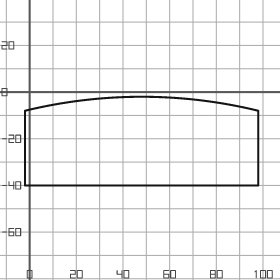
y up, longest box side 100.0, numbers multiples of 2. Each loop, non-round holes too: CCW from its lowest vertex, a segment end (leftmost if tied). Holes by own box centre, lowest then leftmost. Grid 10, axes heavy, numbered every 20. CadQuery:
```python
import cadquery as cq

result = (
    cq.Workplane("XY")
    .moveTo(-2.0, -40.0)
    .lineTo(98.0, -40.0)
    .lineTo(98.0, -8.0)
    .threePointArc((48.0, -2.0), (-2.0, -8.0))
    .close()
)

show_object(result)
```